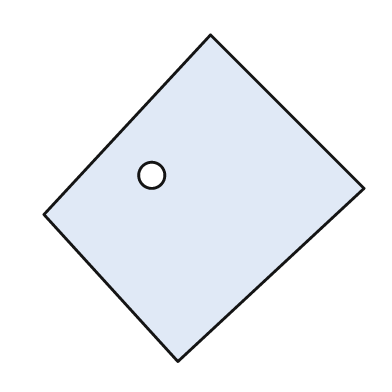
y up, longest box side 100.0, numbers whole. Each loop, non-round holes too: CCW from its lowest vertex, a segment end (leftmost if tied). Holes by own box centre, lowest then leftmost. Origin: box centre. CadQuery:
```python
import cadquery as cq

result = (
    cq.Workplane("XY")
    .moveTo(-8.0, -50.0)
    .lineTo(49.0, 3.0)
    .lineTo(2.0, 50.0)
    .lineTo(-49.0, -5.0)
    .close()
    .moveTo(-16.0, 7.0)
    .circle(4.0)
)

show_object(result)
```